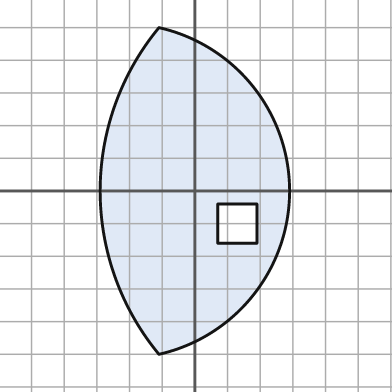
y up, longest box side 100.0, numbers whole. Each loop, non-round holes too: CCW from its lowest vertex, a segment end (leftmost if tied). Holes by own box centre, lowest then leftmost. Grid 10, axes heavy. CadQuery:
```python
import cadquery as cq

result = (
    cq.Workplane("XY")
    .moveTo(-11.0, -50.0)
    .threePointArc((29.0, 0.0), (-11.0, 50.0))
    .threePointArc((-29.0, 0.0), (-11.0, -50.0))
    .close()
    .moveTo(7.0, -16.0)
    .lineTo(19.0, -16.0)
    .lineTo(19.0, -4.0)
    .lineTo(7.0, -4.0)
    .close()
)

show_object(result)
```